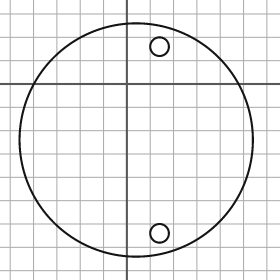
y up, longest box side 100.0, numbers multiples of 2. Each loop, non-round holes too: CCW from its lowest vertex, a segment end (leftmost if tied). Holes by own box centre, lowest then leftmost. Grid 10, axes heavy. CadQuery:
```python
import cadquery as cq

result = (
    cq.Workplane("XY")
    .moveTo(4.0, -24.0)
    .circle(50.0)
    .moveTo(14.0, -64.0)
    .circle(4.0)
    .moveTo(14.0, 16.0)
    .circle(4.0)
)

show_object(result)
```